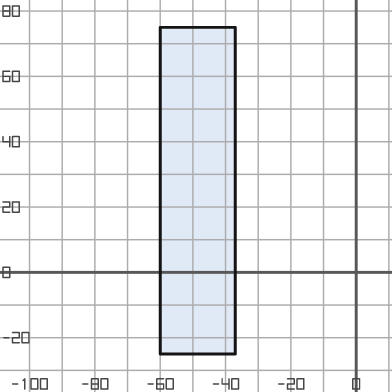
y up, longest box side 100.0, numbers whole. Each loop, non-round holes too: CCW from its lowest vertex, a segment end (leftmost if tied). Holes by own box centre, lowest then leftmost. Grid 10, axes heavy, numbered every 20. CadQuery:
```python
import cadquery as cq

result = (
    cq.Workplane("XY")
    .moveTo(-60.0, -25.0)
    .lineTo(-37.0, -25.0)
    .lineTo(-37.0, 75.0)
    .lineTo(-60.0, 75.0)
    .close()
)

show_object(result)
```